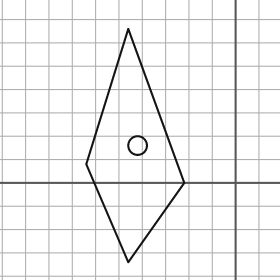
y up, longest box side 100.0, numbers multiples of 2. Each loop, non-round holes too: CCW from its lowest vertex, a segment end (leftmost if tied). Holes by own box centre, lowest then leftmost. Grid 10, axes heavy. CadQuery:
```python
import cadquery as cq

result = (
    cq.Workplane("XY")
    .moveTo(-46.0, -34.0)
    .lineTo(-22.0, 0.0)
    .lineTo(-46.0, 66.0)
    .lineTo(-64.0, 8.0)
    .close()
    .moveTo(-42.0, 16.0)
    .circle(4.0)
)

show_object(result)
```